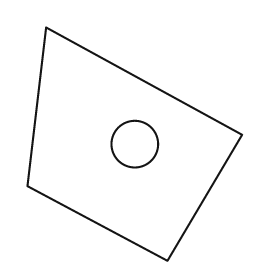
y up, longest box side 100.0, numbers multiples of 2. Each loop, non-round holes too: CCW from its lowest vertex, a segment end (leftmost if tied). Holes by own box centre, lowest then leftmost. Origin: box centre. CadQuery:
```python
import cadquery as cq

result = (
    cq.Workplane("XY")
    .moveTo(14.0, -50.0)
    .lineTo(46.0, 4.0)
    .lineTo(-38.0, 50.0)
    .lineTo(-46.0, -18.0)
    .close()
    .moveTo(0.0, 0.0)
    .circle(10.0)
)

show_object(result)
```